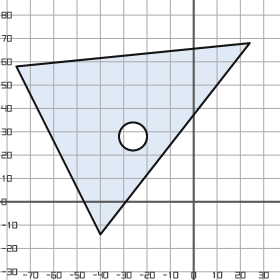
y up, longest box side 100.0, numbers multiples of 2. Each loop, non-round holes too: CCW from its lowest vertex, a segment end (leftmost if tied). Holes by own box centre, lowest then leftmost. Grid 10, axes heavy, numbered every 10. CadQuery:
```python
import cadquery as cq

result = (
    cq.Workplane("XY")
    .moveTo(-40.0, -14.0)
    .lineTo(24.0, 68.0)
    .lineTo(-76.0, 58.0)
    .close()
    .moveTo(-26.0, 28.0)
    .circle(6.0)
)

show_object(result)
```